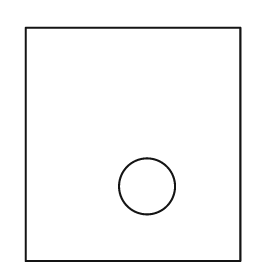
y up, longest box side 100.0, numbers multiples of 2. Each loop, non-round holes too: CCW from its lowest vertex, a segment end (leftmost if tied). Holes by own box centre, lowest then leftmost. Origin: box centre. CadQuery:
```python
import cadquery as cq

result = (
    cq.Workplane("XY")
    .moveTo(-46.0, -50.0)
    .lineTo(46.0, -50.0)
    .lineTo(46.0, 50.0)
    .lineTo(-46.0, 50.0)
    .close()
    .moveTo(6.0, -18.0)
    .circle(12.0)
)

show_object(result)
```